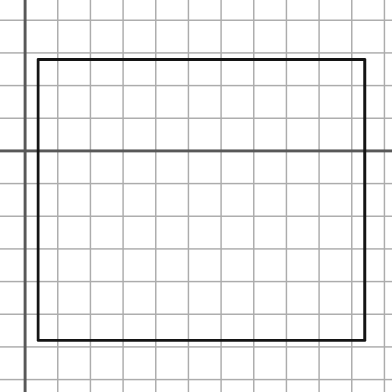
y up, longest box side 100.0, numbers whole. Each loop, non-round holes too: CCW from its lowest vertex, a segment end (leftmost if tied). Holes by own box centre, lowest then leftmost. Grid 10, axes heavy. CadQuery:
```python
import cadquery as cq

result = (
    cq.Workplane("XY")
    .moveTo(4.0, -58.0)
    .lineTo(104.0, -58.0)
    .lineTo(104.0, 28.0)
    .lineTo(4.0, 28.0)
    .close()
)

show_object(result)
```